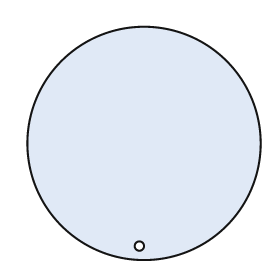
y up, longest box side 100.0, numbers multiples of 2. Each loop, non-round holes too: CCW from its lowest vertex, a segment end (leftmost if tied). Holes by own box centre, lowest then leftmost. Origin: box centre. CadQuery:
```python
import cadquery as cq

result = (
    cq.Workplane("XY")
    .moveTo(0.0, 0.0)
    .circle(50.0)
    .moveTo(-2.0, -44.0)
    .circle(2.0)
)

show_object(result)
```